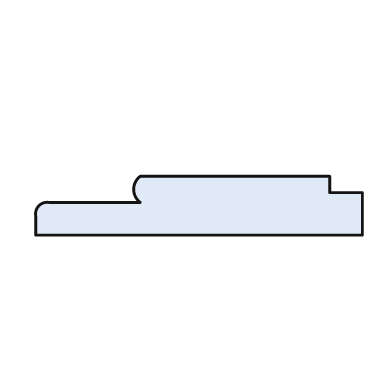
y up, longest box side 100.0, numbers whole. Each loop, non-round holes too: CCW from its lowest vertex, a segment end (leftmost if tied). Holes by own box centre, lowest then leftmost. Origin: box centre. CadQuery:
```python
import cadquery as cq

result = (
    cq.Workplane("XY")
    .moveTo(-50.0, -9.0)
    .lineTo(50.0, -9.0)
    .lineTo(50.0, 4.0)
    .lineTo(40.0, 4.0)
    .lineTo(40.0, 9.0)
    .lineTo(-18.0, 9.0)
    .threePointArc((-20.0, 5.0), (-18.0, 1.0))
    .lineTo(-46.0, 1.0)
    .threePointArc((-49.0, 0.0), (-50.0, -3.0))
    .close()
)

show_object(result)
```